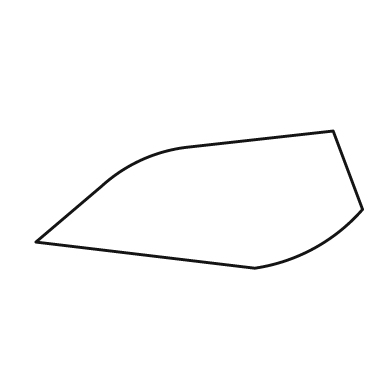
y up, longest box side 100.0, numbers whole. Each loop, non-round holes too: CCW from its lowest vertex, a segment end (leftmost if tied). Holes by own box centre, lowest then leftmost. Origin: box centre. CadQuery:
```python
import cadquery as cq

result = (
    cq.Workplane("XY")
    .moveTo(17.0, -21.0)
    .threePointArc((35.0, -15.0), (50.0, -3.0))
    .lineTo(41.0, 21.0)
    .lineTo(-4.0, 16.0)
    .threePointArc((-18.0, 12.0), (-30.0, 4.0))
    .lineTo(-50.0, -13.0)
    .close()
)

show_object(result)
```